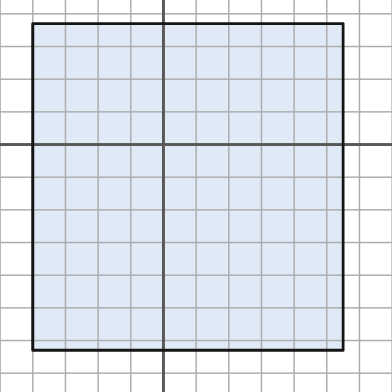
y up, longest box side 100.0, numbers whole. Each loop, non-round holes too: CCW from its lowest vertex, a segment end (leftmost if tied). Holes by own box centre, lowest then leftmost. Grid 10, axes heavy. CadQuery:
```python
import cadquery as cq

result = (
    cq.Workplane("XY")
    .moveTo(-40.0, -63.0)
    .lineTo(55.0, -63.0)
    .lineTo(55.0, 37.0)
    .lineTo(-40.0, 37.0)
    .close()
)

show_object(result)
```